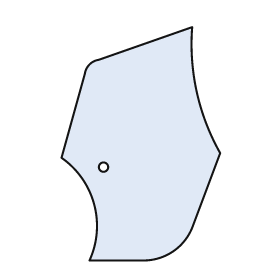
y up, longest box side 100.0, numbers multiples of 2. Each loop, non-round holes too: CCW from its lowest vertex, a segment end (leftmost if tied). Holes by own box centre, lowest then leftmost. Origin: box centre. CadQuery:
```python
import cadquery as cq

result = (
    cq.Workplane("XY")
    .moveTo(-22.0, -50.0)
    .lineTo(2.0, -50.0)
    .threePointArc((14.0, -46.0), (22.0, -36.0))
    .lineTo(34.0, -4.0)
    .threePointArc((24.0, 22.0), (22.0, 50.0))
    .lineTo(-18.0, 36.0)
    .threePointArc((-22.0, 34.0), (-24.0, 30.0))
    .lineTo(-34.0, -6.0)
    .threePointArc((-20.0, -26.0), (-22.0, -50.0))
    .close()
    .moveTo(-16.0, -10.0)
    .circle(2.0)
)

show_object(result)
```